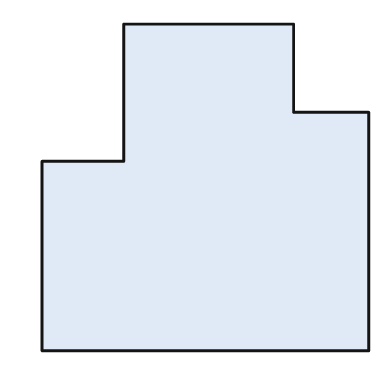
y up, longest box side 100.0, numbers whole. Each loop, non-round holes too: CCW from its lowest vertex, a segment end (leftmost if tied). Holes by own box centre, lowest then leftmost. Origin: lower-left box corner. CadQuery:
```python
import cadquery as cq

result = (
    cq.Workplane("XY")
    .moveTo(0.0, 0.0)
    .lineTo(100.0, 0.0)
    .lineTo(100.0, 73.0)
    .lineTo(77.0, 73.0)
    .lineTo(77.0, 100.0)
    .lineTo(25.0, 100.0)
    .lineTo(25.0, 58.0)
    .lineTo(0.0, 58.0)
    .close()
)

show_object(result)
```